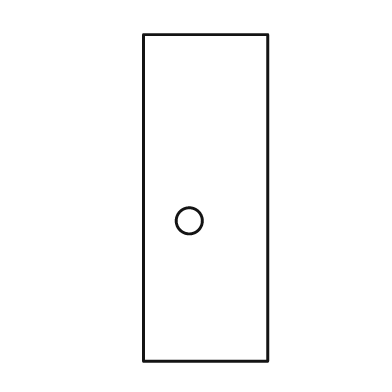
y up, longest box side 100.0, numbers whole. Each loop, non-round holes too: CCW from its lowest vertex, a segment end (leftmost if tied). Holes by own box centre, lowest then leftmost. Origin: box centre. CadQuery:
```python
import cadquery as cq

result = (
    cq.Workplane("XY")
    .moveTo(-19.0, -50.0)
    .lineTo(19.0, -50.0)
    .lineTo(19.0, 50.0)
    .lineTo(-19.0, 50.0)
    .close()
    .moveTo(-5.0, -7.0)
    .circle(4.0)
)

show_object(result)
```